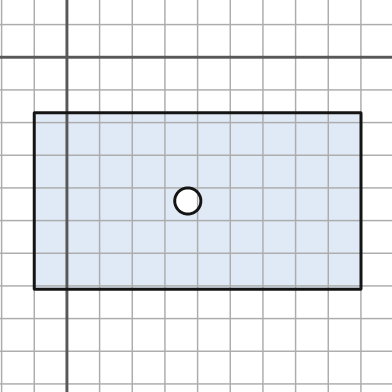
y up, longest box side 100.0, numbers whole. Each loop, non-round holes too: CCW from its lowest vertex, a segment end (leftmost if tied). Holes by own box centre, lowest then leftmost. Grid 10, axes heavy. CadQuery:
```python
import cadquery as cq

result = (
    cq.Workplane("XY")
    .moveTo(-10.0, -71.0)
    .lineTo(90.0, -71.0)
    .lineTo(90.0, -17.0)
    .lineTo(-10.0, -17.0)
    .close()
    .moveTo(37.0, -44.0)
    .circle(4.0)
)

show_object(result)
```